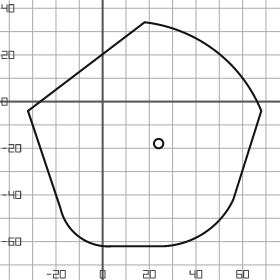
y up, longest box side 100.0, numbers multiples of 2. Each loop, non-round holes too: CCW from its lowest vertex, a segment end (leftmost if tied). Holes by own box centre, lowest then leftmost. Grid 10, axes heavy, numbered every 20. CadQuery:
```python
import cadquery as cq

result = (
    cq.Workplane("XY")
    .moveTo(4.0, -62.0)
    .lineTo(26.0, -62.0)
    .threePointArc((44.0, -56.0), (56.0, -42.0))
    .lineTo(68.0, -4.0)
    .threePointArc((48.0, 22.0), (18.0, 34.0))
    .lineTo(-32.0, -4.0)
    .lineTo(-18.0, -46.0)
    .threePointArc((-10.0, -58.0), (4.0, -62.0))
    .close()
    .moveTo(24.0, -18.0)
    .circle(2.0)
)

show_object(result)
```